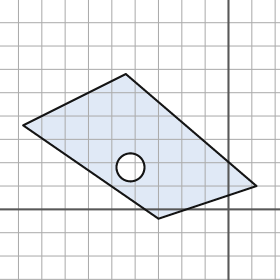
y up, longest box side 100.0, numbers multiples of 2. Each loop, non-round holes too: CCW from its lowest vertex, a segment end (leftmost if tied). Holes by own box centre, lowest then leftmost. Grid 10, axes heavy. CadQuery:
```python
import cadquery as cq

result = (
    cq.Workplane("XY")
    .moveTo(-30.0, -4.0)
    .lineTo(12.0, 10.0)
    .lineTo(-44.0, 58.0)
    .lineTo(-88.0, 36.0)
    .close()
    .moveTo(-42.0, 18.0)
    .circle(6.0)
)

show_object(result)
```